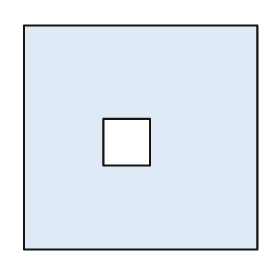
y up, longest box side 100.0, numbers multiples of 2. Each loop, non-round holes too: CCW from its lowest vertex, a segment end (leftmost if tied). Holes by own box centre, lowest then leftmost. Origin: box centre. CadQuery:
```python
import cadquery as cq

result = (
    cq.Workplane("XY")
    .moveTo(-50.0, -48.0)
    .lineTo(50.0, -48.0)
    .lineTo(50.0, 48.0)
    .lineTo(-50.0, 48.0)
    .close()
    .moveTo(-16.0, -12.0)
    .lineTo(4.0, -12.0)
    .lineTo(4.0, 8.0)
    .lineTo(-16.0, 8.0)
    .close()
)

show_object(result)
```